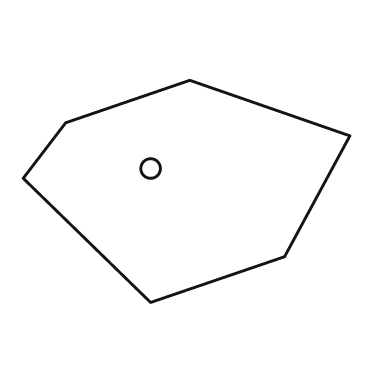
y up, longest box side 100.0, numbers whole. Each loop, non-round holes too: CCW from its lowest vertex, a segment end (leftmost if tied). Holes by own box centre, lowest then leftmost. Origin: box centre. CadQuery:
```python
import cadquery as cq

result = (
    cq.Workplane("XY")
    .moveTo(-11.0, -34.0)
    .lineTo(30.0, -20.0)
    .lineTo(50.0, 17.0)
    .lineTo(1.0, 34.0)
    .lineTo(-37.0, 21.0)
    .lineTo(-50.0, 4.0)
    .close()
    .moveTo(-11.0, 7.0)
    .circle(3.0)
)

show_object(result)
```